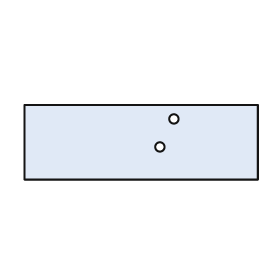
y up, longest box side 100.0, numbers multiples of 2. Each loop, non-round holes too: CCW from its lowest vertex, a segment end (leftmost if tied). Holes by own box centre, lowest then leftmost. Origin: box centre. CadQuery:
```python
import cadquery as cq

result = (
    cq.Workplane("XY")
    .moveTo(-50.0, -16.0)
    .lineTo(50.0, -16.0)
    .lineTo(50.0, 16.0)
    .lineTo(-50.0, 16.0)
    .close()
    .moveTo(8.0, -2.0)
    .circle(2.0)
    .moveTo(14.0, 10.0)
    .circle(2.0)
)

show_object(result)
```